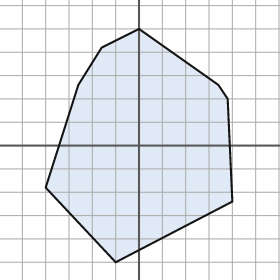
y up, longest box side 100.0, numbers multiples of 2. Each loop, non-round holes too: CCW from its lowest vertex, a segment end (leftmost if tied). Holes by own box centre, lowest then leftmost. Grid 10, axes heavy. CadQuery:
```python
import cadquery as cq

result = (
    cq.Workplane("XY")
    .moveTo(-10.0, -50.0)
    .lineTo(40.0, -24.0)
    .lineTo(38.0, 20.0)
    .lineTo(34.0, 26.0)
    .lineTo(0.0, 50.0)
    .lineTo(-16.0, 42.0)
    .lineTo(-26.0, 26.0)
    .lineTo(-40.0, -18.0)
    .close()
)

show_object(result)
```